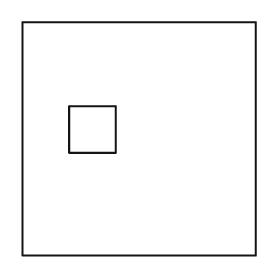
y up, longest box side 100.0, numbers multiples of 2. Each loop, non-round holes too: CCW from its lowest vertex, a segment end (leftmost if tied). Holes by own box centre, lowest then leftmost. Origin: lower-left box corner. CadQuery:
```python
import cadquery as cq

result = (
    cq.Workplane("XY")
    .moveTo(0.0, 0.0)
    .lineTo(100.0, 0.0)
    .lineTo(100.0, 100.0)
    .lineTo(0.0, 100.0)
    .close()
    .moveTo(20.0, 44.0)
    .lineTo(40.0, 44.0)
    .lineTo(40.0, 64.0)
    .lineTo(20.0, 64.0)
    .close()
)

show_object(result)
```